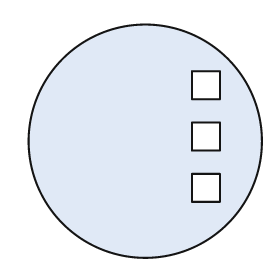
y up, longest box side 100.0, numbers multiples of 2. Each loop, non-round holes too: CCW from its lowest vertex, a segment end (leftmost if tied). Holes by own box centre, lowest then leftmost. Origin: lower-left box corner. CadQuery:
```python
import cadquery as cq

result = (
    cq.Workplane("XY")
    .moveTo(50.0, 50.0)
    .circle(50.0)
    .moveTo(70.0, 24.0)
    .lineTo(82.0, 24.0)
    .lineTo(82.0, 36.0)
    .lineTo(70.0, 36.0)
    .close()
    .moveTo(70.0, 46.0)
    .lineTo(82.0, 46.0)
    .lineTo(82.0, 58.0)
    .lineTo(70.0, 58.0)
    .close()
    .moveTo(70.0, 68.0)
    .lineTo(82.0, 68.0)
    .lineTo(82.0, 80.0)
    .lineTo(70.0, 80.0)
    .close()
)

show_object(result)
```